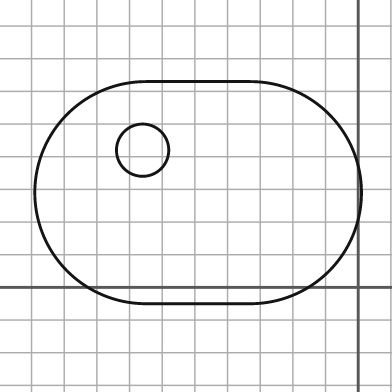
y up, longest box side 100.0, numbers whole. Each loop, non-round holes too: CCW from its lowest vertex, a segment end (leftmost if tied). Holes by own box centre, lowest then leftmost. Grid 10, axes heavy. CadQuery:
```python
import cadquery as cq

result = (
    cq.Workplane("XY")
    .moveTo(-65.0, -5.0)
    .lineTo(-33.0, -5.0)
    .threePointArc((1.0, 29.0), (-33.0, 63.0))
    .lineTo(-65.0, 63.0)
    .threePointArc((-99.0, 29.0), (-65.0, -5.0))
    .close()
    .moveTo(-66.0, 42.0)
    .circle(8.0)
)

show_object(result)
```